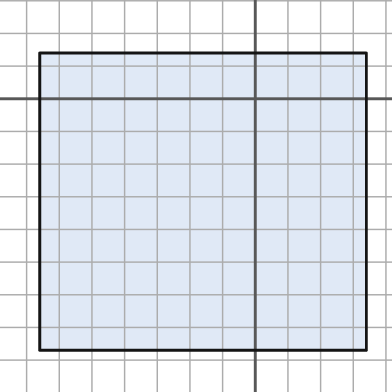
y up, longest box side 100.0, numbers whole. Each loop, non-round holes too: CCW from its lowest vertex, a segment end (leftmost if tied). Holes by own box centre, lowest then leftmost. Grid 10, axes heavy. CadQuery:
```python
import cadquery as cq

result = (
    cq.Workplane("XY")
    .moveTo(-66.0, -77.0)
    .lineTo(34.0, -77.0)
    .lineTo(34.0, 14.0)
    .lineTo(-66.0, 14.0)
    .close()
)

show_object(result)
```